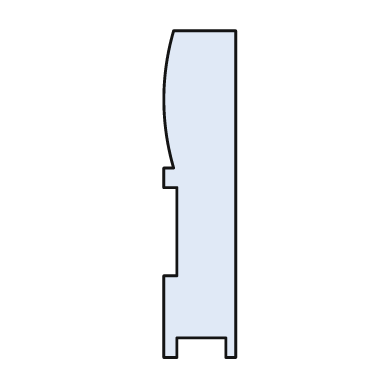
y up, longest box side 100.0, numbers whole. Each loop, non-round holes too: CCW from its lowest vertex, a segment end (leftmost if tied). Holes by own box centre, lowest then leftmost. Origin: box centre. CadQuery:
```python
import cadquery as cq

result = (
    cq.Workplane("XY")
    .moveTo(-11.0, -50.0)
    .lineTo(-7.0, -50.0)
    .lineTo(-7.0, -44.0)
    .lineTo(8.0, -44.0)
    .lineTo(8.0, -50.0)
    .lineTo(11.0, -50.0)
    .lineTo(11.0, 50.0)
    .lineTo(-8.0, 50.0)
    .threePointArc((-11.0, 29.0), (-8.0, 8.0))
    .lineTo(-11.0, 8.0)
    .lineTo(-11.0, 2.0)
    .lineTo(-7.0, 2.0)
    .lineTo(-7.0, -25.0)
    .lineTo(-11.0, -25.0)
    .close()
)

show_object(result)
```